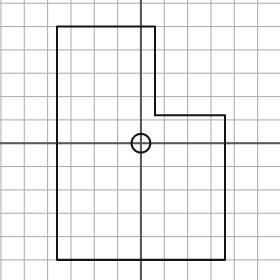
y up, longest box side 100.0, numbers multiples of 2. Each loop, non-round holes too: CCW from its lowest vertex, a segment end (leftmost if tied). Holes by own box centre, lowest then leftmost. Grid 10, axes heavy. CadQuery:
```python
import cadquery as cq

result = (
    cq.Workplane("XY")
    .moveTo(-36.0, -50.0)
    .lineTo(36.0, -50.0)
    .lineTo(36.0, 12.0)
    .lineTo(6.0, 12.0)
    .lineTo(6.0, 50.0)
    .lineTo(-36.0, 50.0)
    .close()
    .moveTo(0.0, 0.0)
    .circle(4.0)
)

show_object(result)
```